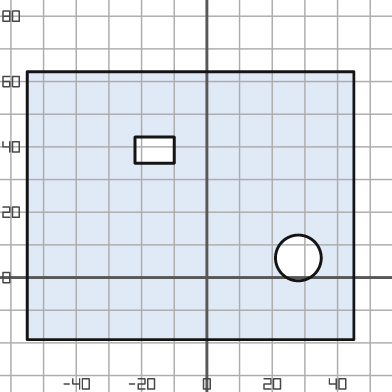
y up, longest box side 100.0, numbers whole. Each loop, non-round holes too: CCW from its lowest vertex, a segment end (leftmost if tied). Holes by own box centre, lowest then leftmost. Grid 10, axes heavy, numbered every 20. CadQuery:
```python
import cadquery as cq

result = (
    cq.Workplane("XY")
    .moveTo(-55.0, -19.0)
    .lineTo(45.0, -19.0)
    .lineTo(45.0, 63.0)
    .lineTo(-55.0, 63.0)
    .close()
    .moveTo(28.0, 6.0)
    .circle(7.0)
    .moveTo(-22.0, 35.0)
    .lineTo(-10.0, 35.0)
    .lineTo(-10.0, 43.0)
    .lineTo(-22.0, 43.0)
    .close()
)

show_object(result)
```